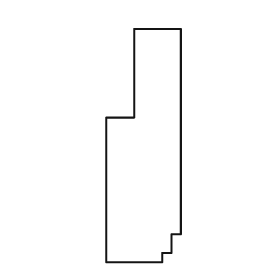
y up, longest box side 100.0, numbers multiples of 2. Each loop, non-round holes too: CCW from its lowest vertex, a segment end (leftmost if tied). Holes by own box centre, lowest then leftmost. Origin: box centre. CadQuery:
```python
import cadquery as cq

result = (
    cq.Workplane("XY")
    .moveTo(-16.0, -50.0)
    .lineTo(8.0, -50.0)
    .lineTo(8.0, -46.0)
    .lineTo(12.0, -46.0)
    .lineTo(12.0, -38.0)
    .lineTo(16.0, -38.0)
    .lineTo(16.0, 50.0)
    .lineTo(-4.0, 50.0)
    .lineTo(-4.0, 12.0)
    .lineTo(-16.0, 12.0)
    .close()
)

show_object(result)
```